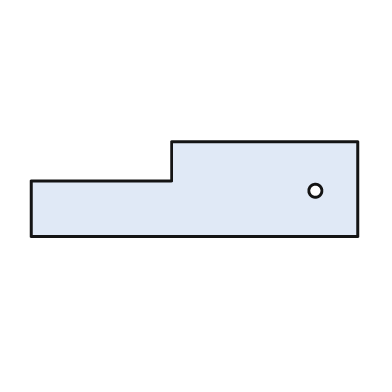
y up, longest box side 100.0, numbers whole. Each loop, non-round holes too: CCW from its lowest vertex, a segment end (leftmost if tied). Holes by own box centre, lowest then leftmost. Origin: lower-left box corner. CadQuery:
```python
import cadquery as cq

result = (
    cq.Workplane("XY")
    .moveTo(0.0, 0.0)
    .lineTo(100.0, 0.0)
    .lineTo(100.0, 29.0)
    .lineTo(43.0, 29.0)
    .lineTo(43.0, 17.0)
    .lineTo(0.0, 17.0)
    .close()
    .moveTo(87.0, 14.0)
    .circle(2.0)
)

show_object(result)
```